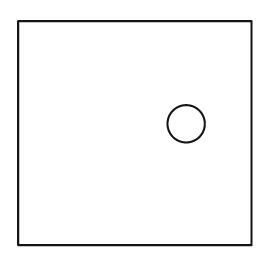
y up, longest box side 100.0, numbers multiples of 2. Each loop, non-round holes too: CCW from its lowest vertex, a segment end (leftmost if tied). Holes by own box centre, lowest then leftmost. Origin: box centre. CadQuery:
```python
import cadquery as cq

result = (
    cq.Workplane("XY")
    .moveTo(-50.0, -48.0)
    .lineTo(50.0, -48.0)
    .lineTo(50.0, 48.0)
    .lineTo(-50.0, 48.0)
    .close()
    .moveTo(22.0, 4.0)
    .circle(8.0)
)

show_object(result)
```